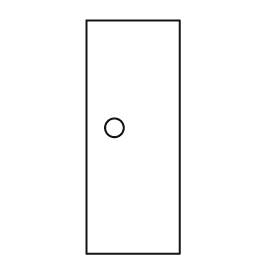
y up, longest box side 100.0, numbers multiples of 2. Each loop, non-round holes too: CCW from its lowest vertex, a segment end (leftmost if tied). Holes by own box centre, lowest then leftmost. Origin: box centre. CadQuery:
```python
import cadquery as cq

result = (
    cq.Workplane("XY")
    .moveTo(-20.0, -50.0)
    .lineTo(20.0, -50.0)
    .lineTo(20.0, 50.0)
    .lineTo(-20.0, 50.0)
    .close()
    .moveTo(-8.0, 4.0)
    .circle(4.0)
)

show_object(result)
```